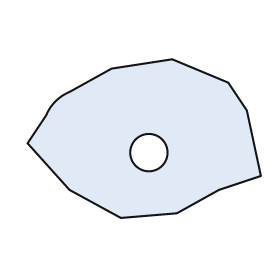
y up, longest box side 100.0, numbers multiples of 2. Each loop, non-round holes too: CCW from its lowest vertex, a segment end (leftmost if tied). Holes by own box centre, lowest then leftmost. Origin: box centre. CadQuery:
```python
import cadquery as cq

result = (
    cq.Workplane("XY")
    .moveTo(-10.0, -34.0)
    .lineTo(14.0, -32.0)
    .lineTo(32.0, -22.0)
    .lineTo(50.0, -16.0)
    .lineTo(44.0, 12.0)
    .lineTo(36.0, 24.0)
    .lineTo(12.0, 34.0)
    .lineTo(-14.0, 30.0)
    .lineTo(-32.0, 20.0)
    .threePointArc((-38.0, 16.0), (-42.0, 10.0))
    .lineTo(-50.0, -2.0)
    .lineTo(-32.0, -22.0)
    .close()
    .moveTo(2.0, -6.0)
    .circle(8.0)
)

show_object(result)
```